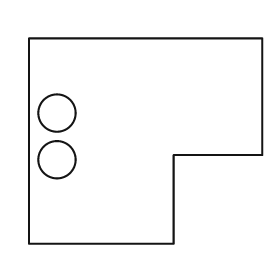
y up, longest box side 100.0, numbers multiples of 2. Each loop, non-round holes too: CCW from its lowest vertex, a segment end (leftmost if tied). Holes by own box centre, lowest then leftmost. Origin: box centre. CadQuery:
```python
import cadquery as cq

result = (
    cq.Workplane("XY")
    .moveTo(-50.0, -44.0)
    .lineTo(12.0, -44.0)
    .lineTo(12.0, -6.0)
    .lineTo(50.0, -6.0)
    .lineTo(50.0, 44.0)
    .lineTo(-50.0, 44.0)
    .close()
    .moveTo(-38.0, -8.0)
    .circle(8.0)
    .moveTo(-38.0, 12.0)
    .circle(8.0)
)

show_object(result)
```